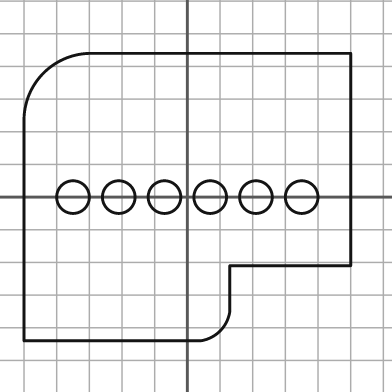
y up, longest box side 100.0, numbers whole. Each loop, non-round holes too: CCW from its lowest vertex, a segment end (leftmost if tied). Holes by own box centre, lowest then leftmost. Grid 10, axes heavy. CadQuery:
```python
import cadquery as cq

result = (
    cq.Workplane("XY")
    .moveTo(-50.0, -44.0)
    .lineTo(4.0, -44.0)
    .threePointArc((10.0, -41.0), (13.0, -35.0))
    .lineTo(13.0, -21.0)
    .lineTo(50.0, -21.0)
    .lineTo(50.0, 44.0)
    .lineTo(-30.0, 44.0)
    .threePointArc((-44.0, 38.0), (-50.0, 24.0))
    .close()
    .moveTo(-35.0, 0.0)
    .circle(5.0)
    .moveTo(-21.0, 0.0)
    .circle(5.0)
    .moveTo(-7.0, 0.0)
    .circle(5.0)
    .moveTo(7.0, 0.0)
    .circle(5.0)
    .moveTo(21.0, 0.0)
    .circle(5.0)
    .moveTo(35.0, 0.0)
    .circle(5.0)
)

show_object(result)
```